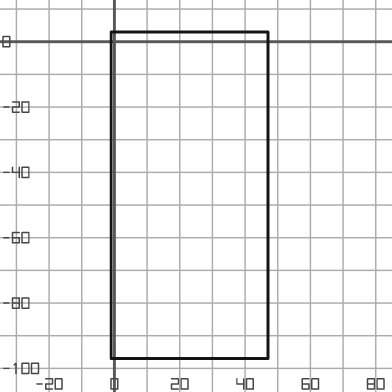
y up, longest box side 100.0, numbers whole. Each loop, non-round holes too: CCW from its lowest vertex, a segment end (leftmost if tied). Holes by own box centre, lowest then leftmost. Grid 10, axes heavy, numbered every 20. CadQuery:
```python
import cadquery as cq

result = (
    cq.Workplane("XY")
    .moveTo(-1.0, -97.0)
    .lineTo(47.0, -97.0)
    .lineTo(47.0, 3.0)
    .lineTo(-1.0, 3.0)
    .close()
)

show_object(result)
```